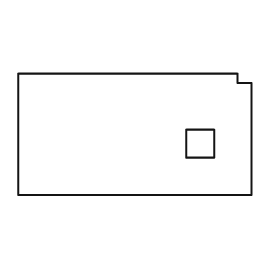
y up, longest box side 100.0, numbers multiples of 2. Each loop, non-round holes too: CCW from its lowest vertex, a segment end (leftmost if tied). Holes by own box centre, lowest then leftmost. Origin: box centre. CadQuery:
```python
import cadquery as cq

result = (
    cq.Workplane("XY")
    .moveTo(-50.0, -26.0)
    .lineTo(50.0, -26.0)
    .lineTo(50.0, 22.0)
    .lineTo(44.0, 22.0)
    .lineTo(44.0, 26.0)
    .lineTo(-50.0, 26.0)
    .close()
    .moveTo(22.0, -10.0)
    .lineTo(34.0, -10.0)
    .lineTo(34.0, 2.0)
    .lineTo(22.0, 2.0)
    .close()
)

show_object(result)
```